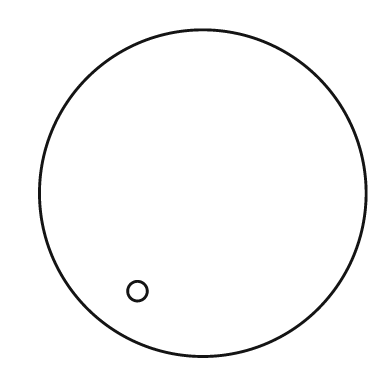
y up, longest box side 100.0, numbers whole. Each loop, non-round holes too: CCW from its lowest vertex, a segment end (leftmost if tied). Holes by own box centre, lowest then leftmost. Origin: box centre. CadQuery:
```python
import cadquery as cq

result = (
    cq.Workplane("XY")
    .moveTo(0.0, 0.0)
    .circle(50.0)
    .moveTo(-20.0, -30.0)
    .circle(3.0)
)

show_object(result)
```